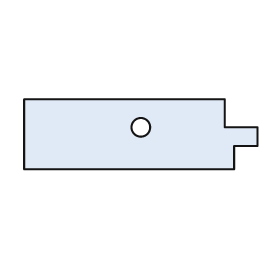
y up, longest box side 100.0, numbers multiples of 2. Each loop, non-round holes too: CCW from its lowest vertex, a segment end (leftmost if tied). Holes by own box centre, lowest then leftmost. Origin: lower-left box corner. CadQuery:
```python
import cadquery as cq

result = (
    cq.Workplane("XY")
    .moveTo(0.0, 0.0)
    .lineTo(90.0, 0.0)
    .lineTo(90.0, 10.0)
    .lineTo(100.0, 10.0)
    .lineTo(100.0, 18.0)
    .lineTo(86.0, 18.0)
    .lineTo(86.0, 30.0)
    .lineTo(0.0, 30.0)
    .close()
    .moveTo(50.0, 18.0)
    .circle(4.0)
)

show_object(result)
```